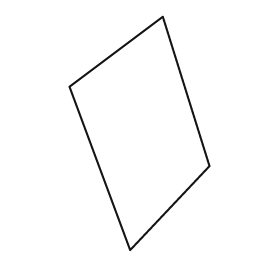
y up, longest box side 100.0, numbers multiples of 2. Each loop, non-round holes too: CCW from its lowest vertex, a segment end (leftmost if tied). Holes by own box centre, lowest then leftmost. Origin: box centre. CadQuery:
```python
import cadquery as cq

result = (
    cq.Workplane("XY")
    .moveTo(-4.0, -50.0)
    .lineTo(30.0, -14.0)
    .lineTo(10.0, 50.0)
    .lineTo(-30.0, 20.0)
    .close()
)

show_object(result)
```